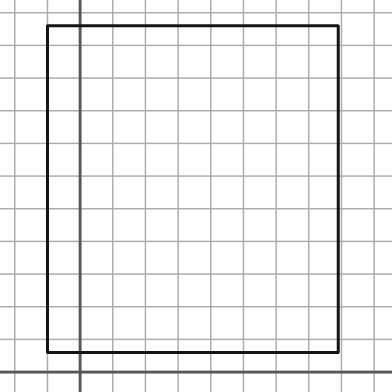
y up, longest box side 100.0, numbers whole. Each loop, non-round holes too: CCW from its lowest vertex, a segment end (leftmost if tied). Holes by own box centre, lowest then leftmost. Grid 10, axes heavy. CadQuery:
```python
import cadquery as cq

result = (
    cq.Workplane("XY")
    .moveTo(-10.0, 6.0)
    .lineTo(79.0, 6.0)
    .lineTo(79.0, 106.0)
    .lineTo(-10.0, 106.0)
    .close()
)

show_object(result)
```